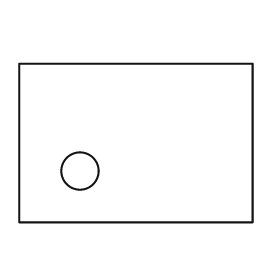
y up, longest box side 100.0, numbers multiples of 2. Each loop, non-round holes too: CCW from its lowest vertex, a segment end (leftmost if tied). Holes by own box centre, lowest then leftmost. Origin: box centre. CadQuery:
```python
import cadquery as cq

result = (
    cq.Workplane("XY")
    .moveTo(-50.0, -34.0)
    .lineTo(50.0, -34.0)
    .lineTo(50.0, 34.0)
    .lineTo(-50.0, 34.0)
    .close()
    .moveTo(-24.0, -12.0)
    .circle(8.0)
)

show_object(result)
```